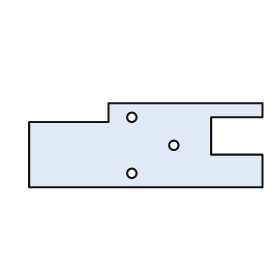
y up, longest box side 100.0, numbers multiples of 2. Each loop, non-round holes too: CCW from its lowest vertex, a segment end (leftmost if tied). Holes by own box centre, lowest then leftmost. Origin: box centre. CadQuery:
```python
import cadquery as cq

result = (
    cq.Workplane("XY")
    .moveTo(-50.0, -18.0)
    .lineTo(50.0, -18.0)
    .lineTo(50.0, -4.0)
    .lineTo(28.0, -4.0)
    .lineTo(28.0, 12.0)
    .lineTo(50.0, 12.0)
    .lineTo(50.0, 18.0)
    .lineTo(-16.0, 18.0)
    .lineTo(-16.0, 10.0)
    .lineTo(-50.0, 10.0)
    .close()
    .moveTo(-6.0, -12.0)
    .circle(2.0)
    .moveTo(12.0, 0.0)
    .circle(2.0)
    .moveTo(-6.0, 12.0)
    .circle(2.0)
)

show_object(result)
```